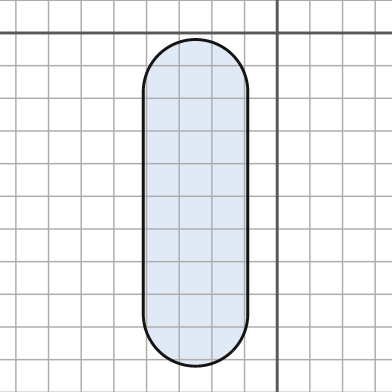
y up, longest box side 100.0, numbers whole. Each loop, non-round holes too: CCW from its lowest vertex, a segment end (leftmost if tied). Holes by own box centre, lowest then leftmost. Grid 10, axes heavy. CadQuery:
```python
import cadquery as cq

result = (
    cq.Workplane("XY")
    .moveTo(-41.0, -86.0)
    .threePointArc((-25.0, -102.0), (-9.0, -86.0))
    .lineTo(-9.0, -18.0)
    .threePointArc((-25.0, -2.0), (-41.0, -18.0))
    .close()
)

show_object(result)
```